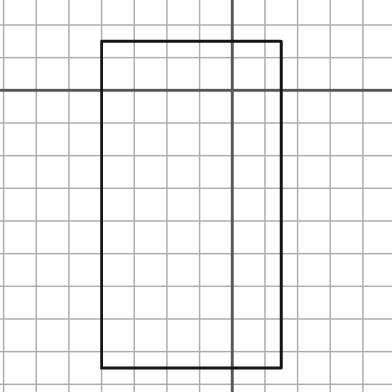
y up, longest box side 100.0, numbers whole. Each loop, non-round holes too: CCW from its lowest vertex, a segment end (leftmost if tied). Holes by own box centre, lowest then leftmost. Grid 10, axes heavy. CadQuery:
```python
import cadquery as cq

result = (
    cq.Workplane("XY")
    .moveTo(-40.0, -85.0)
    .lineTo(15.0, -85.0)
    .lineTo(15.0, 15.0)
    .lineTo(-40.0, 15.0)
    .close()
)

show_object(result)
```